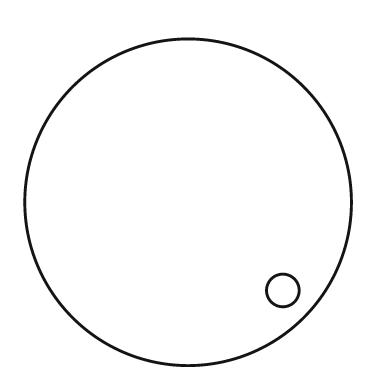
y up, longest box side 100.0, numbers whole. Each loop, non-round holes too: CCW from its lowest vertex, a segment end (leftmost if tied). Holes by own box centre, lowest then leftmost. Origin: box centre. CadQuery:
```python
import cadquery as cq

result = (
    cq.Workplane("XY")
    .moveTo(0.0, 0.0)
    .circle(50.0)
    .moveTo(29.0, -27.0)
    .circle(5.0)
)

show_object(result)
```